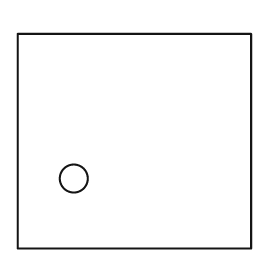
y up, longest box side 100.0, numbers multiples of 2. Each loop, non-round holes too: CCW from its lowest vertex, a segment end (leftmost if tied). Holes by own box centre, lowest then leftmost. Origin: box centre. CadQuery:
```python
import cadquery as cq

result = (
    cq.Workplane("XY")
    .moveTo(-50.0, -46.0)
    .lineTo(50.0, -46.0)
    .lineTo(50.0, 46.0)
    .lineTo(-50.0, 46.0)
    .close()
    .moveTo(-26.0, -16.0)
    .circle(6.0)
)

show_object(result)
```